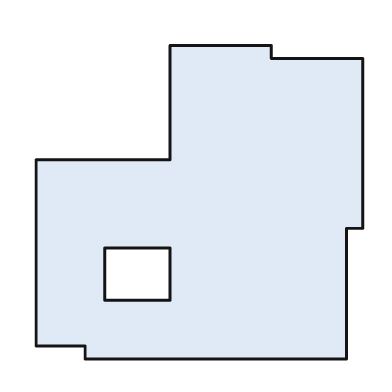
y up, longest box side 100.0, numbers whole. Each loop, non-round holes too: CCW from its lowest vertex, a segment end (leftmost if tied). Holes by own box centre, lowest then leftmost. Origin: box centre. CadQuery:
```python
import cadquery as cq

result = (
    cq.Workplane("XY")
    .moveTo(-35.0, -48.0)
    .lineTo(45.0, -48.0)
    .lineTo(45.0, -8.0)
    .lineTo(50.0, -8.0)
    .lineTo(50.0, 44.0)
    .lineTo(22.0, 44.0)
    .lineTo(22.0, 48.0)
    .lineTo(-9.0, 48.0)
    .lineTo(-9.0, 13.0)
    .lineTo(-50.0, 13.0)
    .lineTo(-50.0, -44.0)
    .lineTo(-35.0, -44.0)
    .close()
    .moveTo(-29.0, -30.0)
    .lineTo(-9.0, -30.0)
    .lineTo(-9.0, -14.0)
    .lineTo(-29.0, -14.0)
    .close()
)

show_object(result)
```